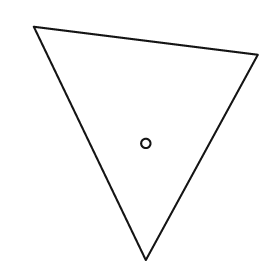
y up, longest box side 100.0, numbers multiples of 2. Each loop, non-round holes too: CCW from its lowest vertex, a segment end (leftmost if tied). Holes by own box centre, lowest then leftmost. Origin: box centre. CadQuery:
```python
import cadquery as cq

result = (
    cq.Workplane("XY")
    .moveTo(0.0, -50.0)
    .lineTo(48.0, 38.0)
    .lineTo(-48.0, 50.0)
    .close()
    .moveTo(0.0, 0.0)
    .circle(2.0)
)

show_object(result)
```